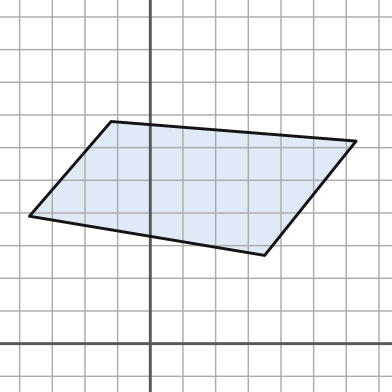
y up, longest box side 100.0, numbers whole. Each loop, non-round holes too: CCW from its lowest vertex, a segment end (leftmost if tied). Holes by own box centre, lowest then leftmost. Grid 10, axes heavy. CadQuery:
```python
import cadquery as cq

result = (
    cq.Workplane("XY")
    .moveTo(35.0, 27.0)
    .lineTo(63.0, 62.0)
    .lineTo(-12.0, 68.0)
    .lineTo(-37.0, 39.0)
    .close()
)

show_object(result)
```